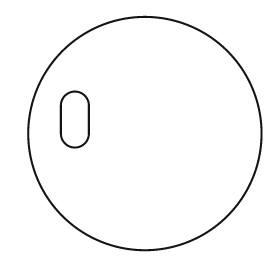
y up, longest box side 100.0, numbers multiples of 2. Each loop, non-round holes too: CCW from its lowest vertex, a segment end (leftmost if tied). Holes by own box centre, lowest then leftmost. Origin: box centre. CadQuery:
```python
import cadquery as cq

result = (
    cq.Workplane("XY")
    .moveTo(0.0, 0.0)
    .circle(50.0)
    .moveTo(-36.0, 0.0)
    .threePointArc((-30.0, -6.0), (-24.0, 0.0))
    .lineTo(-24.0, 12.0)
    .threePointArc((-30.0, 18.0), (-36.0, 12.0))
    .close()
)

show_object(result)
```